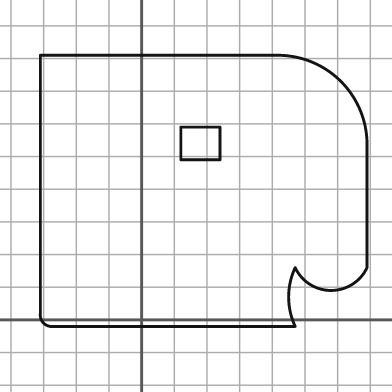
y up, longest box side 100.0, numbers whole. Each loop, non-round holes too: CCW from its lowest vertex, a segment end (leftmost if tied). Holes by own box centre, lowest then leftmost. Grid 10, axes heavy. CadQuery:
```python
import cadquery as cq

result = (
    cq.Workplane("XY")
    .moveTo(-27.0, -2.0)
    .lineTo(47.0, -2.0)
    .threePointArc((45.0, 7.0), (47.0, 16.0))
    .threePointArc((58.0, 9.0), (69.0, 16.0))
    .lineTo(69.0, 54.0)
    .threePointArc((61.0, 73.0), (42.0, 81.0))
    .lineTo(-31.0, 81.0)
    .lineTo(-31.0, 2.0)
    .threePointArc((-30.0, -1.0), (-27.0, -2.0))
    .close()
    .moveTo(12.0, 49.0)
    .lineTo(24.0, 49.0)
    .lineTo(24.0, 59.0)
    .lineTo(12.0, 59.0)
    .close()
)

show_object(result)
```